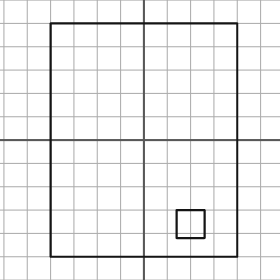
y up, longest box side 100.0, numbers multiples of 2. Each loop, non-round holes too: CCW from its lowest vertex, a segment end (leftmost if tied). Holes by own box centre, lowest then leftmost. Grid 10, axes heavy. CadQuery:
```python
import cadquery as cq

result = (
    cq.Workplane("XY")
    .moveTo(-40.0, -50.0)
    .lineTo(40.0, -50.0)
    .lineTo(40.0, 50.0)
    .lineTo(-40.0, 50.0)
    .close()
    .moveTo(14.0, -42.0)
    .lineTo(26.0, -42.0)
    .lineTo(26.0, -30.0)
    .lineTo(14.0, -30.0)
    .close()
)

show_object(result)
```